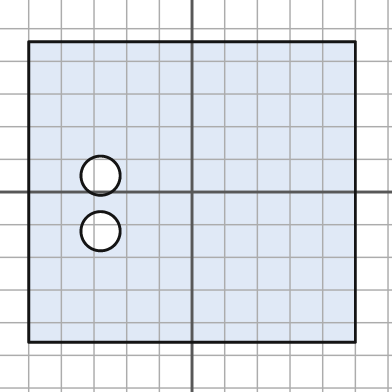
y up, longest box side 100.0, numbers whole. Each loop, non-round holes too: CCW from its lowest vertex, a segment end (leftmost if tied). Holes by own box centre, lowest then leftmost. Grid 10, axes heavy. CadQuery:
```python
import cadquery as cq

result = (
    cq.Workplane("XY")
    .moveTo(-50.0, -46.0)
    .lineTo(50.0, -46.0)
    .lineTo(50.0, 46.0)
    .lineTo(-50.0, 46.0)
    .close()
    .moveTo(-28.0, -12.0)
    .circle(6.0)
    .moveTo(-28.0, 5.0)
    .circle(6.0)
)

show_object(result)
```